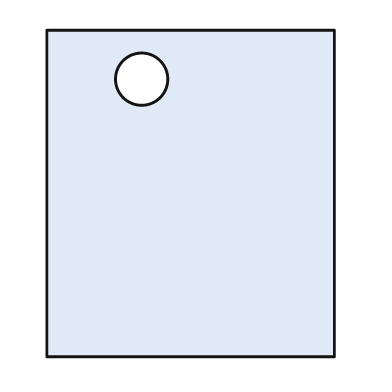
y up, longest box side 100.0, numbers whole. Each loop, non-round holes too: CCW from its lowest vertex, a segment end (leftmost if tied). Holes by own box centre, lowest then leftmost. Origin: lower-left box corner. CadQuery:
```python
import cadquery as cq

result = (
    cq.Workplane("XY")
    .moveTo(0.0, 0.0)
    .lineTo(88.0, 0.0)
    .lineTo(88.0, 100.0)
    .lineTo(0.0, 100.0)
    .close()
    .moveTo(29.0, 85.0)
    .circle(8.0)
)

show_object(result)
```